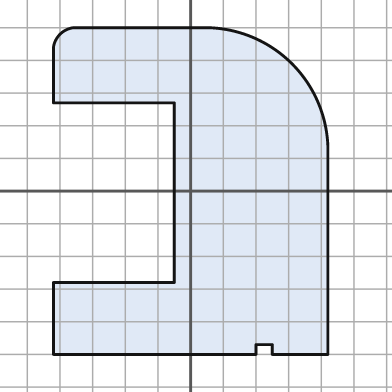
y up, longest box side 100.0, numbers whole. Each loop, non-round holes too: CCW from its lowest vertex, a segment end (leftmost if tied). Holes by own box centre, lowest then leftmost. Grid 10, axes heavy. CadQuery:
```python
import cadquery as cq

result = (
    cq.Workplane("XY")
    .moveTo(-42.0, -50.0)
    .lineTo(20.0, -50.0)
    .lineTo(20.0, -47.0)
    .lineTo(25.0, -47.0)
    .lineTo(25.0, -50.0)
    .lineTo(42.0, -50.0)
    .lineTo(42.0, 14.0)
    .threePointArc((31.0, 39.0), (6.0, 50.0))
    .lineTo(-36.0, 50.0)
    .threePointArc((-40.0, 48.0), (-42.0, 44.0))
    .lineTo(-42.0, 27.0)
    .lineTo(-5.0, 27.0)
    .lineTo(-5.0, -28.0)
    .lineTo(-42.0, -28.0)
    .close()
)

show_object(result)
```